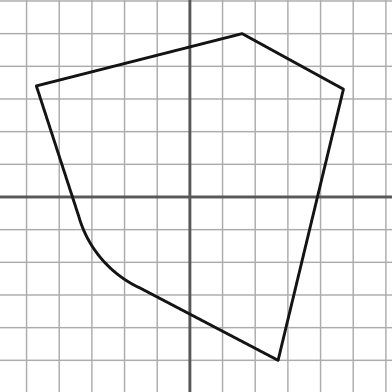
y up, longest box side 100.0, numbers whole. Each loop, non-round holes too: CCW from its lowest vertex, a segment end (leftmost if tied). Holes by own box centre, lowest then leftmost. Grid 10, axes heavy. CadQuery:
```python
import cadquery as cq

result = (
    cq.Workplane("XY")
    .moveTo(27.0, -50.0)
    .lineTo(47.0, 33.0)
    .lineTo(16.0, 50.0)
    .lineTo(-47.0, 34.0)
    .lineTo(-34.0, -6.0)
    .threePointArc((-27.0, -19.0), (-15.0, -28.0))
    .close()
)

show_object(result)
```